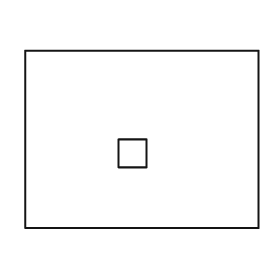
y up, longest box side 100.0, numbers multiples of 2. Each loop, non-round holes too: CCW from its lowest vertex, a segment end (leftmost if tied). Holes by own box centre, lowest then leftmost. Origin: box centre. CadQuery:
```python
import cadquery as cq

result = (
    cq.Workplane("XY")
    .moveTo(-50.0, -38.0)
    .lineTo(50.0, -38.0)
    .lineTo(50.0, 38.0)
    .lineTo(-50.0, 38.0)
    .close()
    .moveTo(-10.0, -12.0)
    .lineTo(2.0, -12.0)
    .lineTo(2.0, 0.0)
    .lineTo(-10.0, 0.0)
    .close()
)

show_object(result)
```